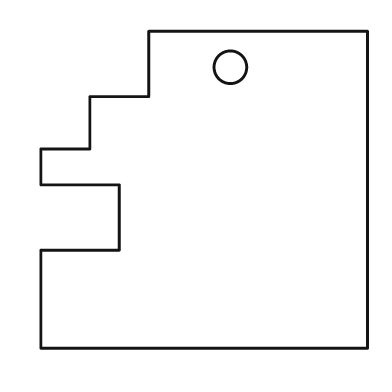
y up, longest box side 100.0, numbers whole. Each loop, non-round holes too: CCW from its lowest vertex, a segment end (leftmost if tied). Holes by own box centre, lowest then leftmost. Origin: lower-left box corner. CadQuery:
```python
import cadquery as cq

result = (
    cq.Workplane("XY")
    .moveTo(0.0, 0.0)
    .lineTo(100.0, 0.0)
    .lineTo(100.0, 97.0)
    .lineTo(33.0, 97.0)
    .lineTo(33.0, 77.0)
    .lineTo(15.0, 77.0)
    .lineTo(15.0, 61.0)
    .lineTo(0.0, 61.0)
    .lineTo(0.0, 50.0)
    .lineTo(24.0, 50.0)
    .lineTo(24.0, 30.0)
    .lineTo(0.0, 30.0)
    .close()
    .moveTo(58.0, 86.0)
    .circle(5.0)
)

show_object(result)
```